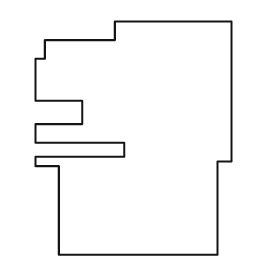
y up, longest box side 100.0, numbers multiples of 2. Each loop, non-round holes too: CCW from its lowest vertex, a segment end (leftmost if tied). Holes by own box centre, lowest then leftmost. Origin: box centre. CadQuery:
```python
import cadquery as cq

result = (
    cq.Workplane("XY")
    .moveTo(-32.0, -50.0)
    .lineTo(36.0, -50.0)
    .lineTo(36.0, -10.0)
    .lineTo(42.0, -10.0)
    .lineTo(42.0, 50.0)
    .lineTo(-8.0, 50.0)
    .lineTo(-8.0, 42.0)
    .lineTo(-38.0, 42.0)
    .lineTo(-38.0, 34.0)
    .lineTo(-42.0, 34.0)
    .lineTo(-42.0, 16.0)
    .lineTo(-22.0, 16.0)
    .lineTo(-22.0, 6.0)
    .lineTo(-42.0, 6.0)
    .lineTo(-42.0, -2.0)
    .lineTo(-4.0, -2.0)
    .lineTo(-4.0, -8.0)
    .lineTo(-42.0, -8.0)
    .lineTo(-42.0, -12.0)
    .lineTo(-32.0, -12.0)
    .close()
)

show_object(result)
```